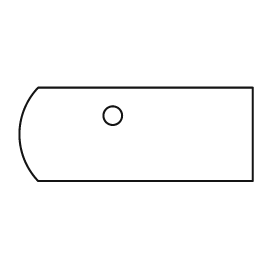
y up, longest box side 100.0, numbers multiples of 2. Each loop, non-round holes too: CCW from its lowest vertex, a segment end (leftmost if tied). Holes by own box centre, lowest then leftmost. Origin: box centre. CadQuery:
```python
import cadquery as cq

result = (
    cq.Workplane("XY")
    .moveTo(-42.0, -20.0)
    .lineTo(50.0, -20.0)
    .lineTo(50.0, 20.0)
    .lineTo(-42.0, 20.0)
    .threePointArc((-50.0, 0.0), (-42.0, -20.0))
    .close()
    .moveTo(-10.0, 8.0)
    .circle(4.0)
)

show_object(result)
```